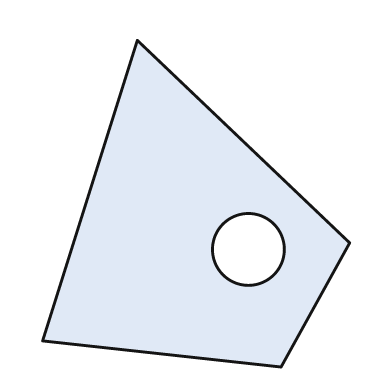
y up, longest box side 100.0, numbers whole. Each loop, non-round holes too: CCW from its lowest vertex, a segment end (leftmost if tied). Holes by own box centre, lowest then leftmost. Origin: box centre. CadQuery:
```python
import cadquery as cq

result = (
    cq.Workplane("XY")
    .moveTo(26.0, -50.0)
    .lineTo(47.0, -12.0)
    .lineTo(-18.0, 50.0)
    .lineTo(-47.0, -42.0)
    .close()
    .moveTo(16.0, -14.0)
    .circle(11.0)
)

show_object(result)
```